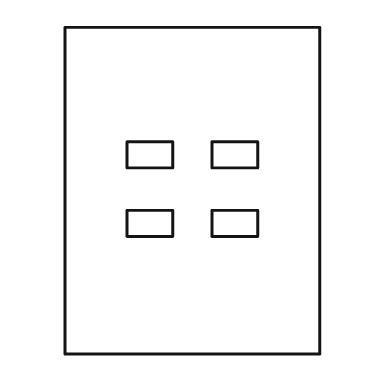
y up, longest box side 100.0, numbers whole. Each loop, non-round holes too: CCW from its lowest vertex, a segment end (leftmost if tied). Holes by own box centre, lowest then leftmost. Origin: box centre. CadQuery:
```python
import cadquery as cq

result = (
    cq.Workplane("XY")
    .moveTo(-39.0, -50.0)
    .lineTo(39.0, -50.0)
    .lineTo(39.0, 50.0)
    .lineTo(-39.0, 50.0)
    .close()
    .moveTo(-20.0, -14.0)
    .lineTo(-6.0, -14.0)
    .lineTo(-6.0, -6.0)
    .lineTo(-20.0, -6.0)
    .close()
    .moveTo(6.0, -14.0)
    .lineTo(20.0, -14.0)
    .lineTo(20.0, -6.0)
    .lineTo(6.0, -6.0)
    .close()
    .moveTo(-20.0, 7.0)
    .lineTo(-6.0, 7.0)
    .lineTo(-6.0, 15.0)
    .lineTo(-20.0, 15.0)
    .close()
    .moveTo(6.0, 7.0)
    .lineTo(20.0, 7.0)
    .lineTo(20.0, 15.0)
    .lineTo(6.0, 15.0)
    .close()
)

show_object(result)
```